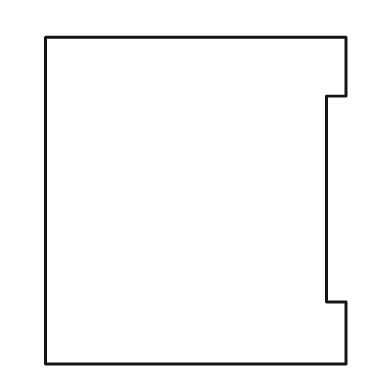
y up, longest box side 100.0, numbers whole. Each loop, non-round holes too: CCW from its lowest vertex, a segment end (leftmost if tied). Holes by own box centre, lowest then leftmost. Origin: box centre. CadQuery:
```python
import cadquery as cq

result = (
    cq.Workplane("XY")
    .moveTo(-46.0, -50.0)
    .lineTo(46.0, -50.0)
    .lineTo(46.0, -31.0)
    .lineTo(40.0, -31.0)
    .lineTo(40.0, 32.0)
    .lineTo(46.0, 32.0)
    .lineTo(46.0, 50.0)
    .lineTo(-46.0, 50.0)
    .close()
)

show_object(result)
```